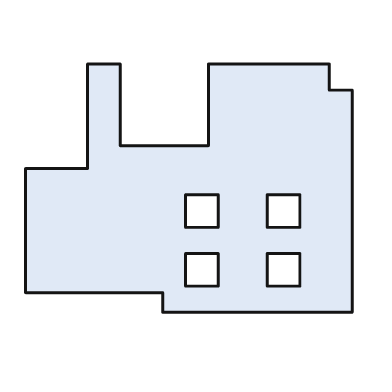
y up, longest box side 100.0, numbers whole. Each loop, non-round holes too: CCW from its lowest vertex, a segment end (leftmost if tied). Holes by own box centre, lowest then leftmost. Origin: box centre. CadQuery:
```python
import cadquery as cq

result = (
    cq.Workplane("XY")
    .moveTo(-8.0, -38.0)
    .lineTo(50.0, -38.0)
    .lineTo(50.0, 30.0)
    .lineTo(43.0, 30.0)
    .lineTo(43.0, 38.0)
    .lineTo(6.0, 38.0)
    .lineTo(6.0, 13.0)
    .lineTo(-21.0, 13.0)
    .lineTo(-21.0, 38.0)
    .lineTo(-31.0, 38.0)
    .lineTo(-31.0, 6.0)
    .lineTo(-50.0, 6.0)
    .lineTo(-50.0, -32.0)
    .lineTo(-8.0, -32.0)
    .close()
    .moveTo(-1.0, -30.0)
    .lineTo(9.0, -30.0)
    .lineTo(9.0, -20.0)
    .lineTo(-1.0, -20.0)
    .close()
    .moveTo(24.0, -30.0)
    .lineTo(34.0, -30.0)
    .lineTo(34.0, -20.0)
    .lineTo(24.0, -20.0)
    .close()
    .moveTo(-1.0, -12.0)
    .lineTo(9.0, -12.0)
    .lineTo(9.0, -2.0)
    .lineTo(-1.0, -2.0)
    .close()
    .moveTo(24.0, -12.0)
    .lineTo(34.0, -12.0)
    .lineTo(34.0, -2.0)
    .lineTo(24.0, -2.0)
    .close()
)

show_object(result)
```